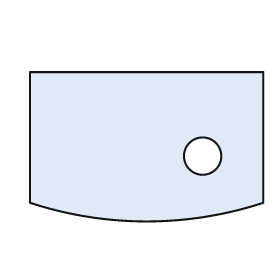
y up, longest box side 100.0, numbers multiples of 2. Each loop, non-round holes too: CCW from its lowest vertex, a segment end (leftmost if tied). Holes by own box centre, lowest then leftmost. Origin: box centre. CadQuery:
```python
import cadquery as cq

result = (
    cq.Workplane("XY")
    .moveTo(-50.0, -24.0)
    .threePointArc((0.0, -32.0), (50.0, -24.0))
    .lineTo(50.0, 32.0)
    .lineTo(-50.0, 32.0)
    .close()
    .moveTo(24.0, -4.0)
    .circle(8.0)
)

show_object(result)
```